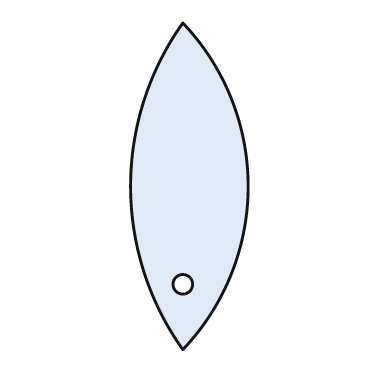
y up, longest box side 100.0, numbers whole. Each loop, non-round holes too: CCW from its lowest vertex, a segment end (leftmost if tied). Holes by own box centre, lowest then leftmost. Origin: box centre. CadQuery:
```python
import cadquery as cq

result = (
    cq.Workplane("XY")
    .moveTo(-2.0, -50.0)
    .threePointArc((18.0, 0.0), (-2.0, 50.0))
    .threePointArc((-18.0, 0.0), (-2.0, -50.0))
    .close()
    .moveTo(-2.0, -30.0)
    .circle(3.0)
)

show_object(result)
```